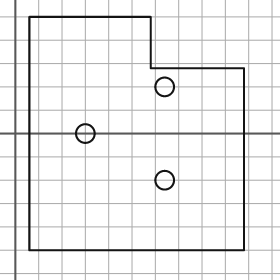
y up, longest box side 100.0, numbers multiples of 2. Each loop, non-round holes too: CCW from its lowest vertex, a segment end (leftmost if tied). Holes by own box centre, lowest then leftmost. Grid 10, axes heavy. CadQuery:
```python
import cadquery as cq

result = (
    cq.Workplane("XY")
    .moveTo(6.0, -50.0)
    .lineTo(98.0, -50.0)
    .lineTo(98.0, 28.0)
    .lineTo(58.0, 28.0)
    .lineTo(58.0, 50.0)
    .lineTo(6.0, 50.0)
    .close()
    .moveTo(64.0, -20.0)
    .circle(4.0)
    .moveTo(30.0, 0.0)
    .circle(4.0)
    .moveTo(64.0, 20.0)
    .circle(4.0)
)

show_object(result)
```